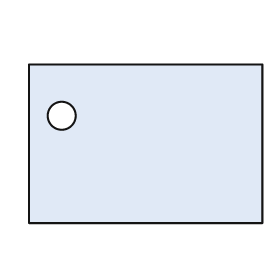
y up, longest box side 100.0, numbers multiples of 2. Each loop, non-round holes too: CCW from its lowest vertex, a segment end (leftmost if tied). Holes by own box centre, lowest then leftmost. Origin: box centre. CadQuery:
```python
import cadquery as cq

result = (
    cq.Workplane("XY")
    .moveTo(-50.0, -34.0)
    .lineTo(50.0, -34.0)
    .lineTo(50.0, 34.0)
    .lineTo(-50.0, 34.0)
    .close()
    .moveTo(-36.0, 12.0)
    .circle(6.0)
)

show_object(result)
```